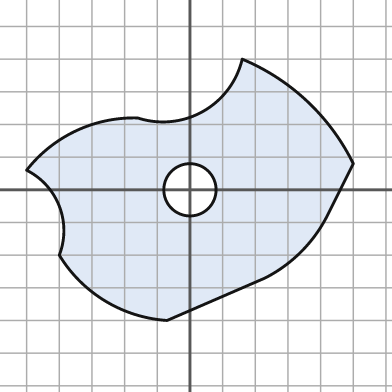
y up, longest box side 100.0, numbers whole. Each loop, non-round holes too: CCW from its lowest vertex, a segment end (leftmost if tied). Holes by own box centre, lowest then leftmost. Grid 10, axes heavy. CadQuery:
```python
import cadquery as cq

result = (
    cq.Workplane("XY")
    .moveTo(-7.0, -40.0)
    .lineTo(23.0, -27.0)
    .threePointArc((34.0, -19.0), (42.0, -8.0))
    .lineTo(50.0, 8.0)
    .threePointArc((36.0, 27.0), (16.0, 40.0))
    .threePointArc((4.0, 24.0), (-16.0, 22.0))
    .threePointArc((-35.0, 18.0), (-50.0, 6.0))
    .threePointArc((-40.0, -5.0), (-40.0, -20.0))
    .threePointArc((-26.0, -34.0), (-7.0, -40.0))
    .close()
    .moveTo(0.0, 0.0)
    .circle(8.0)
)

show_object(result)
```